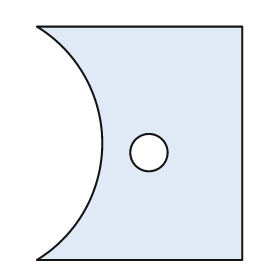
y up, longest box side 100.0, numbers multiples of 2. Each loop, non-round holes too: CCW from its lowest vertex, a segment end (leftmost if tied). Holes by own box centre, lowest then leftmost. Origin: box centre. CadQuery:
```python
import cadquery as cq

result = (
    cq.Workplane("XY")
    .moveTo(-44.0, -50.0)
    .lineTo(44.0, -50.0)
    .lineTo(44.0, 50.0)
    .lineTo(-44.0, 50.0)
    .threePointArc((-16.0, 0.0), (-44.0, -50.0))
    .close()
    .moveTo(4.0, -4.0)
    .circle(8.0)
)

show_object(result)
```